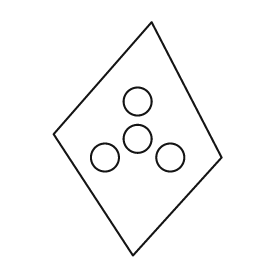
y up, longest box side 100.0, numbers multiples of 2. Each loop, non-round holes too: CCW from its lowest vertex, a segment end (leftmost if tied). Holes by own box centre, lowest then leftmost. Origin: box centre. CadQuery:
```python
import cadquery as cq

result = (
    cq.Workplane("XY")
    .moveTo(-2.0, -50.0)
    .lineTo(36.0, -8.0)
    .lineTo(6.0, 50.0)
    .lineTo(-36.0, 2.0)
    .close()
    .moveTo(-14.0, -8.0)
    .circle(6.0)
    .moveTo(14.0, -8.0)
    .circle(6.0)
    .moveTo(0.0, 0.0)
    .circle(6.0)
    .moveTo(0.0, 16.0)
    .circle(6.0)
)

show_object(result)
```